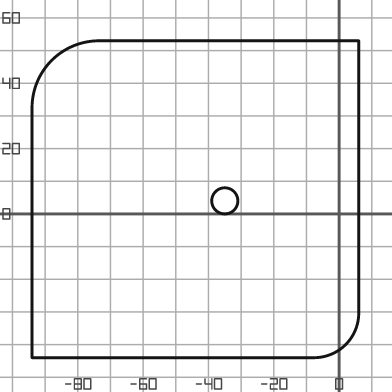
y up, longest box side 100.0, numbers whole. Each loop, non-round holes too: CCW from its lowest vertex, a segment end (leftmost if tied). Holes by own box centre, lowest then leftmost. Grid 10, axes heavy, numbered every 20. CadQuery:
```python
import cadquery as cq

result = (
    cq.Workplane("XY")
    .moveTo(-94.0, -44.0)
    .lineTo(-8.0, -44.0)
    .threePointArc((2.0, -40.0), (6.0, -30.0))
    .lineTo(6.0, 53.0)
    .lineTo(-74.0, 53.0)
    .threePointArc((-88.0, 47.0), (-94.0, 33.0))
    .close()
    .moveTo(-35.0, 4.0)
    .circle(4.0)
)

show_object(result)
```